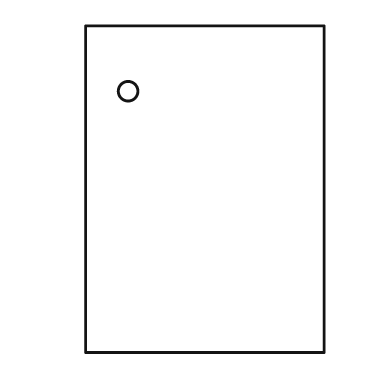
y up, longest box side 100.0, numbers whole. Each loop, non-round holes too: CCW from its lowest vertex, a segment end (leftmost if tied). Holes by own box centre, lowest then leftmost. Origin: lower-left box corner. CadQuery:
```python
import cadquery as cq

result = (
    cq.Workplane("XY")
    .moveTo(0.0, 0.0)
    .lineTo(73.0, 0.0)
    .lineTo(73.0, 100.0)
    .lineTo(0.0, 100.0)
    .close()
    .moveTo(13.0, 80.0)
    .circle(3.0)
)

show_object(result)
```